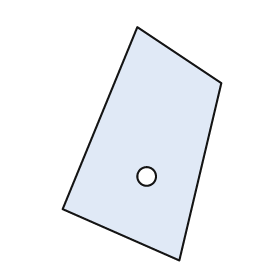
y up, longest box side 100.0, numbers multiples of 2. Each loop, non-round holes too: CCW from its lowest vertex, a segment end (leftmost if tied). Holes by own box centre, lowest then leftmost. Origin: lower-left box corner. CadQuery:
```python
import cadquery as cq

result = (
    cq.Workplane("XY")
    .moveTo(50.0, 0.0)
    .lineTo(68.0, 76.0)
    .lineTo(32.0, 100.0)
    .lineTo(0.0, 22.0)
    .close()
    .moveTo(36.0, 36.0)
    .circle(4.0)
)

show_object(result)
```